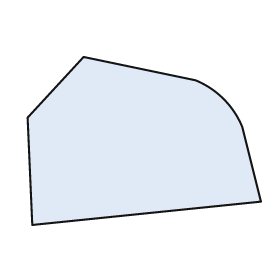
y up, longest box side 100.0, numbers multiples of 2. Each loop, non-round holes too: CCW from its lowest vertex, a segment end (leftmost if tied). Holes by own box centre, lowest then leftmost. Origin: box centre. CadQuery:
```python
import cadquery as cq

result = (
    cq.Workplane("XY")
    .moveTo(-48.0, -36.0)
    .lineTo(50.0, -26.0)
    .lineTo(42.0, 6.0)
    .threePointArc((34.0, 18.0), (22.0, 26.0))
    .lineTo(-26.0, 36.0)
    .lineTo(-50.0, 10.0)
    .close()
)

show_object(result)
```